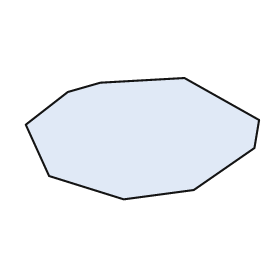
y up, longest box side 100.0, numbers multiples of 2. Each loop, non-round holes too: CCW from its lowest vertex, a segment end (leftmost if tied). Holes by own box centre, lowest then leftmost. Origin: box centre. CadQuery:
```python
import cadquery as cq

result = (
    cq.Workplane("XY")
    .moveTo(-8.0, -26.0)
    .lineTo(22.0, -22.0)
    .lineTo(48.0, -4.0)
    .lineTo(50.0, 8.0)
    .lineTo(18.0, 26.0)
    .lineTo(-18.0, 24.0)
    .lineTo(-32.0, 20.0)
    .lineTo(-50.0, 6.0)
    .lineTo(-40.0, -16.0)
    .close()
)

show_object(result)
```